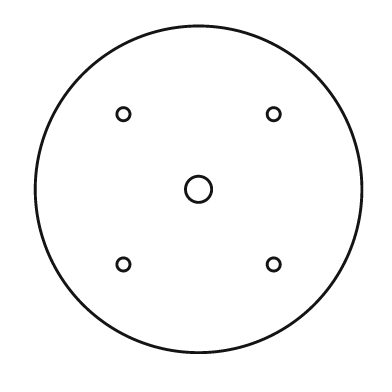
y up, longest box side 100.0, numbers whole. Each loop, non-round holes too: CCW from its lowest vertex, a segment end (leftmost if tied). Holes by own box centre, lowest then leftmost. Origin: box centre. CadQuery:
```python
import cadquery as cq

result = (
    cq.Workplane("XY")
    .moveTo(0.0, 0.0)
    .circle(50.0)
    .moveTo(-23.0, -23.0)
    .circle(2.0)
    .moveTo(23.0, -23.0)
    .circle(2.0)
    .moveTo(0.0, 0.0)
    .circle(4.0)
    .moveTo(-23.0, 23.0)
    .circle(2.0)
    .moveTo(23.0, 23.0)
    .circle(2.0)
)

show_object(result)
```